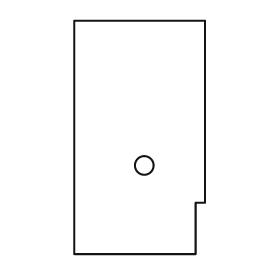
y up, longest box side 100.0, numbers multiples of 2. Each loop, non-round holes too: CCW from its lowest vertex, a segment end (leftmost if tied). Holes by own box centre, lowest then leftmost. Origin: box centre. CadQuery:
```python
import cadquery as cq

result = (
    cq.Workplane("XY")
    .moveTo(-28.0, -50.0)
    .lineTo(24.0, -50.0)
    .lineTo(24.0, -28.0)
    .lineTo(28.0, -28.0)
    .lineTo(28.0, 50.0)
    .lineTo(-28.0, 50.0)
    .close()
    .moveTo(2.0, -12.0)
    .circle(4.0)
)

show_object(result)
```